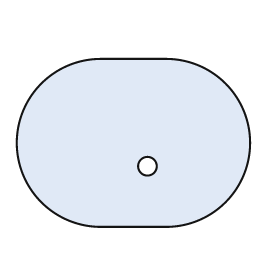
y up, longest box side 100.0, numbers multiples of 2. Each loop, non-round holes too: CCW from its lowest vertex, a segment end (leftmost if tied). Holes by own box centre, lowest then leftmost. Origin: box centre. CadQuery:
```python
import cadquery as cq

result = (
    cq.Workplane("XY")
    .moveTo(-14.0, -36.0)
    .lineTo(14.0, -36.0)
    .threePointArc((50.0, 0.0), (14.0, 36.0))
    .lineTo(-14.0, 36.0)
    .threePointArc((-50.0, 0.0), (-14.0, -36.0))
    .close()
    .moveTo(6.0, -10.0)
    .circle(4.0)
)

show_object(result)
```